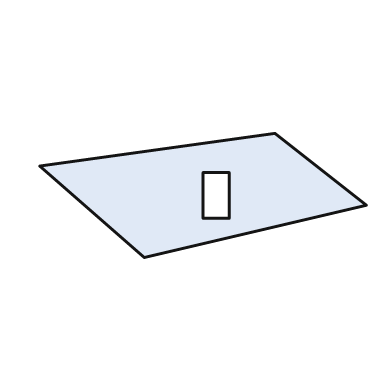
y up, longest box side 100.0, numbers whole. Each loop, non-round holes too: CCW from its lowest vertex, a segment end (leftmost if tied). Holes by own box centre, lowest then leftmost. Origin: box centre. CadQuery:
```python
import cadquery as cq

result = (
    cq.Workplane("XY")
    .moveTo(-18.0, -19.0)
    .lineTo(50.0, -3.0)
    .lineTo(22.0, 19.0)
    .lineTo(-50.0, 9.0)
    .close()
    .moveTo(0.0, -7.0)
    .lineTo(8.0, -7.0)
    .lineTo(8.0, 7.0)
    .lineTo(0.0, 7.0)
    .close()
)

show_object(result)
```